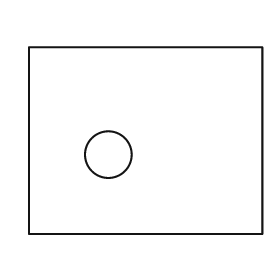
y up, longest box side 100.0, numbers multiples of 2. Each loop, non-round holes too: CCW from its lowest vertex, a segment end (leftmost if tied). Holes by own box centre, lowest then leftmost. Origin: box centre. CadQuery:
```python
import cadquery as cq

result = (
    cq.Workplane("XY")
    .moveTo(-50.0, -40.0)
    .lineTo(50.0, -40.0)
    .lineTo(50.0, 40.0)
    .lineTo(-50.0, 40.0)
    .close()
    .moveTo(-16.0, -6.0)
    .circle(10.0)
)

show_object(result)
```